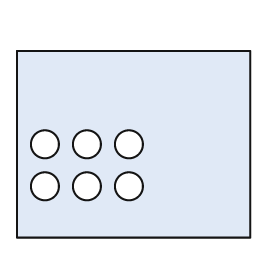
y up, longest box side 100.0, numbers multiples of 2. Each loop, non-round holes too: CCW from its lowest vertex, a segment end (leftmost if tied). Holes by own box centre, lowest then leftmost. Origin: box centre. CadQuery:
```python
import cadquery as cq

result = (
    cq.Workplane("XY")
    .moveTo(-50.0, -40.0)
    .lineTo(50.0, -40.0)
    .lineTo(50.0, 40.0)
    .lineTo(-50.0, 40.0)
    .close()
    .moveTo(-38.0, -18.0)
    .circle(6.0)
    .moveTo(-20.0, -18.0)
    .circle(6.0)
    .moveTo(-2.0, -18.0)
    .circle(6.0)
    .moveTo(-38.0, 0.0)
    .circle(6.0)
    .moveTo(-20.0, 0.0)
    .circle(6.0)
    .moveTo(-2.0, 0.0)
    .circle(6.0)
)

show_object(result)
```